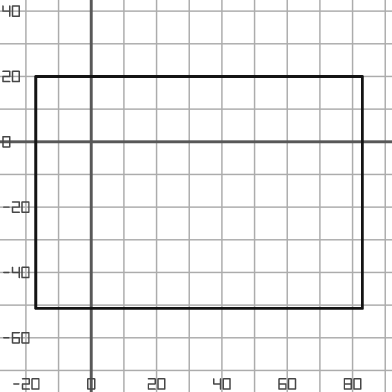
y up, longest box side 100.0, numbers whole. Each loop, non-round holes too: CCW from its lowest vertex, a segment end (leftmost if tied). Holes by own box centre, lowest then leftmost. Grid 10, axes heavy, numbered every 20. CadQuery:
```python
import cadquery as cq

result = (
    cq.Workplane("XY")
    .moveTo(-17.0, -51.0)
    .lineTo(83.0, -51.0)
    .lineTo(83.0, 20.0)
    .lineTo(-17.0, 20.0)
    .close()
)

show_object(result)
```